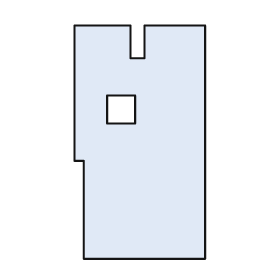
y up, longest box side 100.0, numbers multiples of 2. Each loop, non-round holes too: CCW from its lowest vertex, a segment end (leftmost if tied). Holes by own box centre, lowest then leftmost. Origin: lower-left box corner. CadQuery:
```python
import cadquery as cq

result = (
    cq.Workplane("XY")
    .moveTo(4.0, 0.0)
    .lineTo(56.0, 0.0)
    .lineTo(56.0, 100.0)
    .lineTo(30.0, 100.0)
    .lineTo(30.0, 86.0)
    .lineTo(24.0, 86.0)
    .lineTo(24.0, 100.0)
    .lineTo(0.0, 100.0)
    .lineTo(0.0, 42.0)
    .lineTo(4.0, 42.0)
    .close()
    .moveTo(14.0, 58.0)
    .lineTo(26.0, 58.0)
    .lineTo(26.0, 70.0)
    .lineTo(14.0, 70.0)
    .close()
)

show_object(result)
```